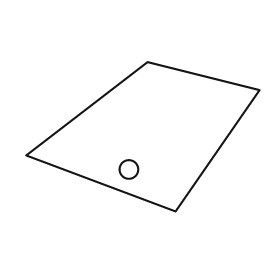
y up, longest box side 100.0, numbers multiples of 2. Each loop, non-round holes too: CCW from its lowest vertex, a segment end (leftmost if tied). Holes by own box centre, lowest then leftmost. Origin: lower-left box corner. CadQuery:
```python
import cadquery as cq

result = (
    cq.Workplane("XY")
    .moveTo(64.0, 0.0)
    .lineTo(100.0, 52.0)
    .lineTo(52.0, 64.0)
    .lineTo(0.0, 24.0)
    .close()
    .moveTo(44.0, 18.0)
    .circle(4.0)
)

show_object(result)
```